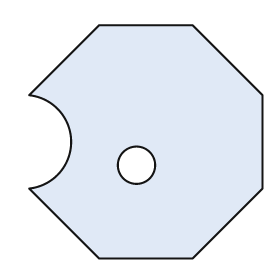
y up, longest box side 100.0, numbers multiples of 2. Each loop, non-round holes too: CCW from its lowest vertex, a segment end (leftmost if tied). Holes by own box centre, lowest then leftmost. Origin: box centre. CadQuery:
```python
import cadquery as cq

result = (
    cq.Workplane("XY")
    .moveTo(-20.0, -50.0)
    .lineTo(20.0, -50.0)
    .lineTo(50.0, -20.0)
    .lineTo(50.0, 20.0)
    .lineTo(20.0, 50.0)
    .lineTo(-20.0, 50.0)
    .lineTo(-50.0, 20.0)
    .threePointArc((-32.0, 0.0), (-50.0, -20.0))
    .close()
    .moveTo(-4.0, -10.0)
    .circle(8.0)
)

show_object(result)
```